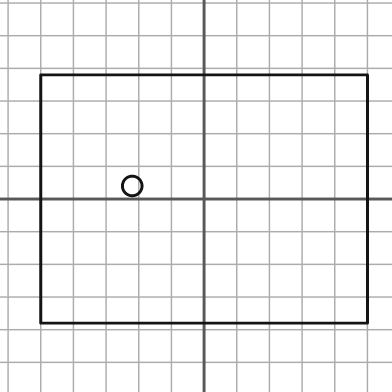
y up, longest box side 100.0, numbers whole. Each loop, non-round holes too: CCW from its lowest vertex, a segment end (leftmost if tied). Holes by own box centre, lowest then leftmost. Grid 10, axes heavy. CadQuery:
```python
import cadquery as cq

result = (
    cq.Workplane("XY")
    .moveTo(-50.0, -38.0)
    .lineTo(50.0, -38.0)
    .lineTo(50.0, 38.0)
    .lineTo(-50.0, 38.0)
    .close()
    .moveTo(-22.0, 4.0)
    .circle(3.0)
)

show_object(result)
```